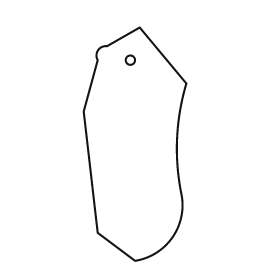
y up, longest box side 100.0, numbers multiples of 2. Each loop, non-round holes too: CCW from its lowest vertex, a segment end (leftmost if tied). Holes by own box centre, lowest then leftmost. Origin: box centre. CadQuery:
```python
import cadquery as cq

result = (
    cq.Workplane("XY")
    .moveTo(0.0, -50.0)
    .threePointArc((16.0, -40.0), (20.0, -22.0))
    .threePointArc((18.0, 2.0), (22.0, 26.0))
    .lineTo(2.0, 50.0)
    .lineTo(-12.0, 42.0)
    .threePointArc((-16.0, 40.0), (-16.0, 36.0))
    .lineTo(-22.0, 14.0)
    .lineTo(-16.0, -38.0)
    .close()
    .moveTo(-2.0, 36.0)
    .circle(2.0)
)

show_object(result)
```